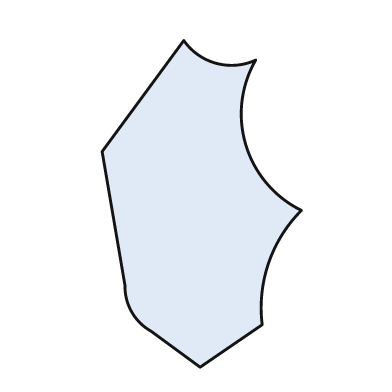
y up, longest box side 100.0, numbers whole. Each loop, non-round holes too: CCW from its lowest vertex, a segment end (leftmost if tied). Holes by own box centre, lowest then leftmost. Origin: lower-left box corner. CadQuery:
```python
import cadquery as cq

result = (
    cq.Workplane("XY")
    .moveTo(30.0, 0.0)
    .lineTo(49.0, 13.0)
    .threePointArc((51.0, 32.0), (61.0, 48.0))
    .threePointArc((44.0, 68.0), (47.0, 94.0))
    .threePointArc((35.0, 93.0), (25.0, 100.0))
    .lineTo(0.0, 66.0)
    .lineTo(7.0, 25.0)
    .threePointArc((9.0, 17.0), (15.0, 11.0))
    .close()
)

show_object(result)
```